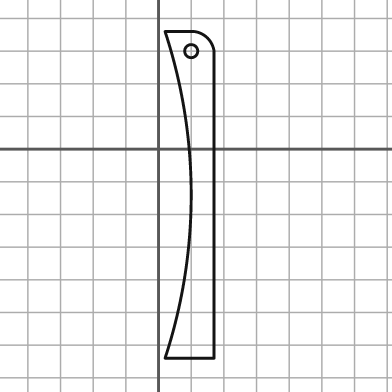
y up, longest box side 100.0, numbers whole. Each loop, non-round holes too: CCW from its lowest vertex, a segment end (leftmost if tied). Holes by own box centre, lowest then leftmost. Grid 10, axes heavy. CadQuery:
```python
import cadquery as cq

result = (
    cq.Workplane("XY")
    .moveTo(2.0, -64.0)
    .lineTo(17.0, -64.0)
    .lineTo(17.0, 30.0)
    .threePointArc((15.0, 34.0), (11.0, 36.0))
    .lineTo(2.0, 36.0)
    .threePointArc((10.0, -14.0), (2.0, -64.0))
    .close()
    .moveTo(10.0, 30.0)
    .circle(2.0)
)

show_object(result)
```